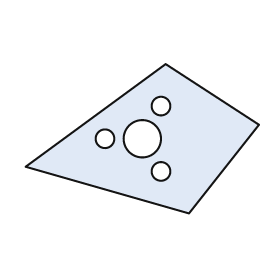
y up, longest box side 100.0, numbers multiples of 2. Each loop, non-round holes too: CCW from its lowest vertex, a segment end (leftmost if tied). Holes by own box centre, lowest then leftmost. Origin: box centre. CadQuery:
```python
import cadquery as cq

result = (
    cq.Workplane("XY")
    .moveTo(20.0, -32.0)
    .lineTo(50.0, 6.0)
    .lineTo(10.0, 32.0)
    .lineTo(-50.0, -12.0)
    .close()
    .moveTo(8.0, -14.0)
    .circle(4.0)
    .moveTo(-16.0, 0.0)
    .circle(4.0)
    .moveTo(0.0, 0.0)
    .circle(8.0)
    .moveTo(8.0, 14.0)
    .circle(4.0)
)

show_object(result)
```